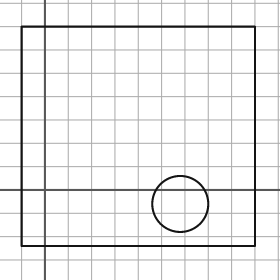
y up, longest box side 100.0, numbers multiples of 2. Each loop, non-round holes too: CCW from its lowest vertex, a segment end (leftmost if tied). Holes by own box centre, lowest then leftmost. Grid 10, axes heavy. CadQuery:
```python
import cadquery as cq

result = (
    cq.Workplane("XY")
    .moveTo(-10.0, -24.0)
    .lineTo(90.0, -24.0)
    .lineTo(90.0, 70.0)
    .lineTo(-10.0, 70.0)
    .close()
    .moveTo(58.0, -6.0)
    .circle(12.0)
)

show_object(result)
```